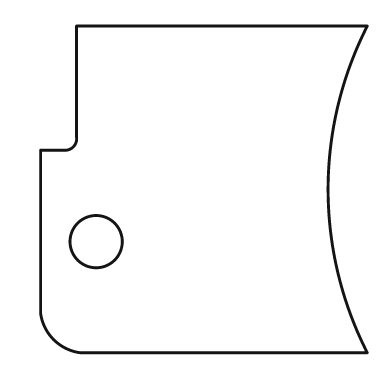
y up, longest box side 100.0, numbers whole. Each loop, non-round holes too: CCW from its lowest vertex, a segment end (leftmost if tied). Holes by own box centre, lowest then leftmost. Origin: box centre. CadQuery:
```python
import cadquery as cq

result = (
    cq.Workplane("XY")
    .moveTo(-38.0, -50.0)
    .lineTo(50.0, -50.0)
    .threePointArc((38.0, 0.0), (50.0, 50.0))
    .lineTo(-39.0, 50.0)
    .lineTo(-39.0, 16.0)
    .threePointArc((-40.0, 13.0), (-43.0, 12.0))
    .lineTo(-50.0, 12.0)
    .lineTo(-50.0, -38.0)
    .threePointArc((-46.0, -46.0), (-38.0, -50.0))
    .close()
    .moveTo(-33.0, -16.0)
    .circle(8.0)
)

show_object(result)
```